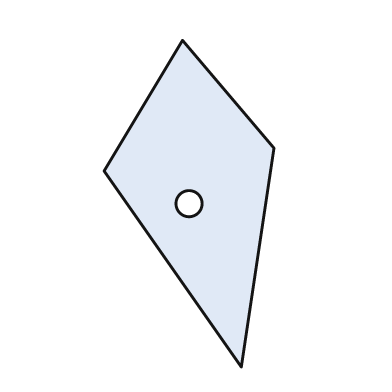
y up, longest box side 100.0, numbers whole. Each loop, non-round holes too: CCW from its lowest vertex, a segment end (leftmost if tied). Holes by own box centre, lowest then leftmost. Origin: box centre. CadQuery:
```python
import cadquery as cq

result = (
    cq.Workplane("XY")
    .moveTo(16.0, -50.0)
    .lineTo(26.0, 17.0)
    .lineTo(-2.0, 50.0)
    .lineTo(-26.0, 10.0)
    .close()
    .moveTo(0.0, 0.0)
    .circle(4.0)
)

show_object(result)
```